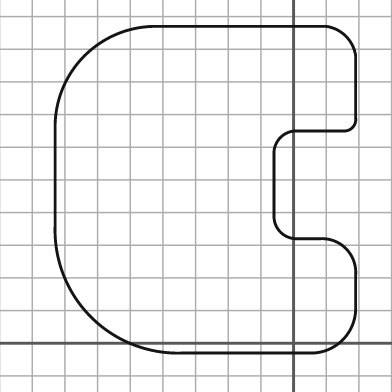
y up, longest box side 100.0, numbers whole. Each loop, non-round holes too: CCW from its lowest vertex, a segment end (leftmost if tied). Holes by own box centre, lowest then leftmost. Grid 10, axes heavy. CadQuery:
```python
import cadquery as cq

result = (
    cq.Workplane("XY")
    .moveTo(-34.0, -3.0)
    .lineTo(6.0, -3.0)
    .threePointArc((15.0, 1.0), (19.0, 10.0))
    .lineTo(19.0, 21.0)
    .threePointArc((16.0, 29.0), (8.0, 32.0))
    .lineTo(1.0, 32.0)
    .threePointArc((-4.0, 34.0), (-6.0, 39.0))
    .lineTo(-6.0, 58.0)
    .threePointArc((-4.0, 63.0), (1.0, 65.0))
    .lineTo(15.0, 65.0)
    .threePointArc((18.0, 66.0), (19.0, 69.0))
    .lineTo(19.0, 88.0)
    .threePointArc((16.0, 94.0), (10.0, 97.0))
    .lineTo(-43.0, 97.0)
    .threePointArc((-64.0, 88.0), (-73.0, 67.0))
    .lineTo(-73.0, 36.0)
    .threePointArc((-62.0, 8.0), (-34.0, -3.0))
    .close()
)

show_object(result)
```